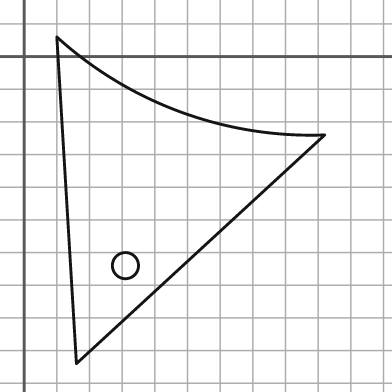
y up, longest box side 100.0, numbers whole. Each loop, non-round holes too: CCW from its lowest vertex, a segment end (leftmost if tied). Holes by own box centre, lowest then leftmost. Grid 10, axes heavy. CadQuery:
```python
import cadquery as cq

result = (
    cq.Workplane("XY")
    .moveTo(16.0, -94.0)
    .lineTo(92.0, -24.0)
    .threePointArc((48.0, -17.0), (10.0, 6.0))
    .close()
    .moveTo(31.0, -64.0)
    .circle(4.0)
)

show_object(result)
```